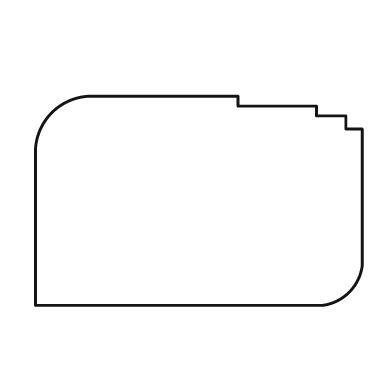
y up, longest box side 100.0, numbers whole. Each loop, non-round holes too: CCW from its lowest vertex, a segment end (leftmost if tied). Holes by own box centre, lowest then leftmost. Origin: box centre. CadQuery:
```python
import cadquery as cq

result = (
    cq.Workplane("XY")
    .moveTo(-50.0, -32.0)
    .lineTo(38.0, -32.0)
    .threePointArc((46.0, -28.0), (50.0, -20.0))
    .lineTo(50.0, 22.0)
    .lineTo(45.0, 22.0)
    .lineTo(45.0, 26.0)
    .lineTo(36.0, 26.0)
    .lineTo(36.0, 29.0)
    .lineTo(12.0, 29.0)
    .lineTo(12.0, 32.0)
    .lineTo(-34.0, 32.0)
    .threePointArc((-45.0, 27.0), (-50.0, 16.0))
    .close()
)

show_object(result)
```